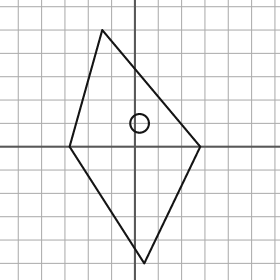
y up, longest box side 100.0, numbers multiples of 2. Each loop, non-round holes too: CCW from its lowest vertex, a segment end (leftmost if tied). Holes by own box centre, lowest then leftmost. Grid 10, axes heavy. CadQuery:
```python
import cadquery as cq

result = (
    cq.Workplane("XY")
    .moveTo(4.0, -50.0)
    .lineTo(28.0, 0.0)
    .lineTo(-14.0, 50.0)
    .lineTo(-28.0, 0.0)
    .close()
    .moveTo(2.0, 10.0)
    .circle(4.0)
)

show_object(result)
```